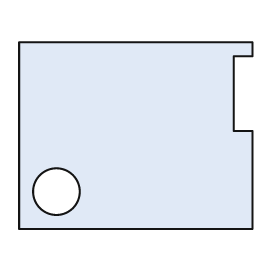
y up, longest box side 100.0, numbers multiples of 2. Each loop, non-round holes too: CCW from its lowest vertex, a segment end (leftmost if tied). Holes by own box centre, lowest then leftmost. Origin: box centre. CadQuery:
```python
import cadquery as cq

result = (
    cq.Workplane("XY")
    .moveTo(-50.0, -40.0)
    .lineTo(50.0, -40.0)
    .lineTo(50.0, 2.0)
    .lineTo(42.0, 2.0)
    .lineTo(42.0, 34.0)
    .lineTo(50.0, 34.0)
    .lineTo(50.0, 40.0)
    .lineTo(-50.0, 40.0)
    .close()
    .moveTo(-34.0, -24.0)
    .circle(10.0)
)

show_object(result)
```